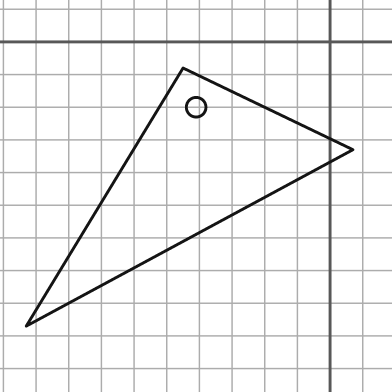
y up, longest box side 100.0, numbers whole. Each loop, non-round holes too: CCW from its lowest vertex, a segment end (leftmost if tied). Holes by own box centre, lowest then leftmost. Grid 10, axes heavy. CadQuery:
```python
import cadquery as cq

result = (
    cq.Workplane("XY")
    .moveTo(-93.0, -87.0)
    .lineTo(7.0, -33.0)
    .lineTo(-45.0, -8.0)
    .close()
    .moveTo(-41.0, -20.0)
    .circle(3.0)
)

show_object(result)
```